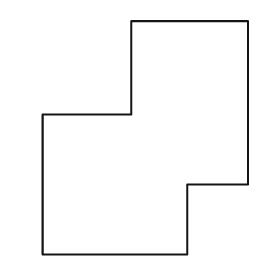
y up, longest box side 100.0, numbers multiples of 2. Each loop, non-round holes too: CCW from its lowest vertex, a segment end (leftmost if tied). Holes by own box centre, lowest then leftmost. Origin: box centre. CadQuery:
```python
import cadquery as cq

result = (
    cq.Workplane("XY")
    .moveTo(-44.0, -50.0)
    .lineTo(18.0, -50.0)
    .lineTo(18.0, -20.0)
    .lineTo(44.0, -20.0)
    .lineTo(44.0, 50.0)
    .lineTo(-6.0, 50.0)
    .lineTo(-6.0, 10.0)
    .lineTo(-44.0, 10.0)
    .close()
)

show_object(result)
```